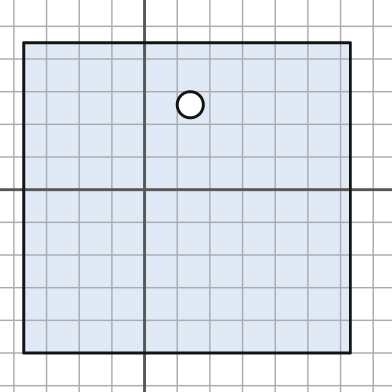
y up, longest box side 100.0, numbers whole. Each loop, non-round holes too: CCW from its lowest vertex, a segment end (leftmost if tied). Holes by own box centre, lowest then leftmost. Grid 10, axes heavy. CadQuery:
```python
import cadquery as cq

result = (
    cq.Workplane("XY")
    .moveTo(-37.0, -50.0)
    .lineTo(63.0, -50.0)
    .lineTo(63.0, 45.0)
    .lineTo(-37.0, 45.0)
    .close()
    .moveTo(14.0, 26.0)
    .circle(4.0)
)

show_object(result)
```